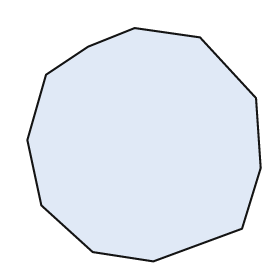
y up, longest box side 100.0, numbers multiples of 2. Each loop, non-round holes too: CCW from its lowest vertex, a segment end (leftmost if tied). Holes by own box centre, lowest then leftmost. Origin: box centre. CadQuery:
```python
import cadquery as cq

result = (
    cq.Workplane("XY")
    .moveTo(4.0, -50.0)
    .lineTo(42.0, -36.0)
    .lineTo(50.0, -10.0)
    .lineTo(48.0, 20.0)
    .lineTo(24.0, 46.0)
    .lineTo(-4.0, 50.0)
    .lineTo(-24.0, 42.0)
    .lineTo(-42.0, 30.0)
    .lineTo(-50.0, 2.0)
    .lineTo(-44.0, -26.0)
    .lineTo(-22.0, -46.0)
    .close()
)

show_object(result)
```